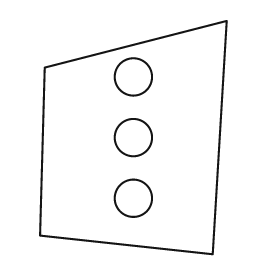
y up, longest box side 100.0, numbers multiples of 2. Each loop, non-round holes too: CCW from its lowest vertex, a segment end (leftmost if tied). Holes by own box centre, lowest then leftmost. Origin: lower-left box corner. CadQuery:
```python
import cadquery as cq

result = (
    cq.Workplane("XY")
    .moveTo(74.0, 0.0)
    .lineTo(80.0, 100.0)
    .lineTo(2.0, 80.0)
    .lineTo(0.0, 8.0)
    .close()
    .moveTo(40.0, 24.0)
    .circle(8.0)
    .moveTo(40.0, 50.0)
    .circle(8.0)
    .moveTo(40.0, 76.0)
    .circle(8.0)
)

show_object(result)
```